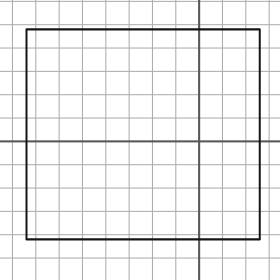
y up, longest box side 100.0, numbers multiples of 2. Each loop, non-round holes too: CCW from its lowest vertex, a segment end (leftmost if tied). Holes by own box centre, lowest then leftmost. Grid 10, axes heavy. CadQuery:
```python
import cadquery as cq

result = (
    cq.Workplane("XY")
    .moveTo(-74.0, -42.0)
    .lineTo(26.0, -42.0)
    .lineTo(26.0, 48.0)
    .lineTo(-74.0, 48.0)
    .close()
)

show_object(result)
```